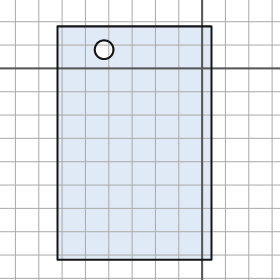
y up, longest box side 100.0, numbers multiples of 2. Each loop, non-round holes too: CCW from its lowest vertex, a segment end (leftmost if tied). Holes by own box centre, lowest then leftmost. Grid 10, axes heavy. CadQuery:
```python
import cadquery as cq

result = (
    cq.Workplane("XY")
    .moveTo(-62.0, -82.0)
    .lineTo(4.0, -82.0)
    .lineTo(4.0, 18.0)
    .lineTo(-62.0, 18.0)
    .close()
    .moveTo(-42.0, 8.0)
    .circle(4.0)
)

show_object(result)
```